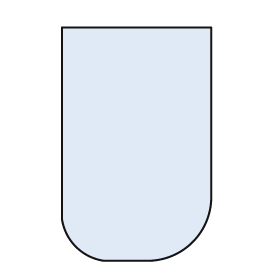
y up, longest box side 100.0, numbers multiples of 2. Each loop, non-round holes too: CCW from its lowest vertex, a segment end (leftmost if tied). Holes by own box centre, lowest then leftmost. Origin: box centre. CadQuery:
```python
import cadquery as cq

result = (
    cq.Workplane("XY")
    .moveTo(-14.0, -50.0)
    .lineTo(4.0, -50.0)
    .threePointArc((24.0, -42.0), (32.0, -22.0))
    .lineTo(32.0, 50.0)
    .lineTo(-32.0, 50.0)
    .lineTo(-32.0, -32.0)
    .threePointArc((-26.0, -44.0), (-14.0, -50.0))
    .close()
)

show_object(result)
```